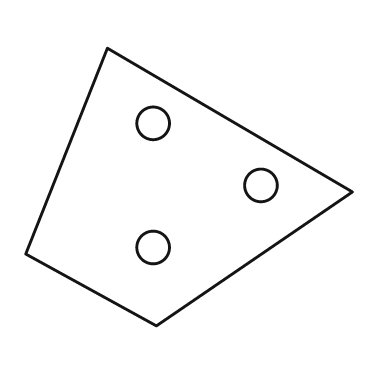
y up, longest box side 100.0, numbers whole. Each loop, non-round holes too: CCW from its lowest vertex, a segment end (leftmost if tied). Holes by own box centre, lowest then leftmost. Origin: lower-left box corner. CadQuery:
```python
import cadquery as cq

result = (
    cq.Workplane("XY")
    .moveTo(40.0, 0.0)
    .lineTo(100.0, 41.0)
    .lineTo(25.0, 85.0)
    .lineTo(0.0, 22.0)
    .close()
    .moveTo(39.0, 24.0)
    .circle(5.0)
    .moveTo(72.0, 43.0)
    .circle(5.0)
    .moveTo(39.0, 62.0)
    .circle(5.0)
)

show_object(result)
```